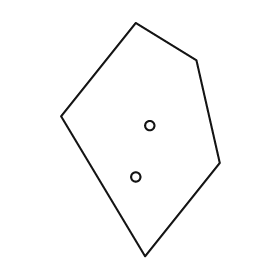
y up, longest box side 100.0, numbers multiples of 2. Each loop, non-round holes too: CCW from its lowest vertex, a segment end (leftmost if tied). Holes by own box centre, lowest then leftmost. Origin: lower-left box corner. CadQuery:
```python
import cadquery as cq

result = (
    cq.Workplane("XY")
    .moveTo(36.0, 0.0)
    .lineTo(68.0, 40.0)
    .lineTo(58.0, 84.0)
    .lineTo(32.0, 100.0)
    .lineTo(0.0, 60.0)
    .close()
    .moveTo(32.0, 34.0)
    .circle(2.0)
    .moveTo(38.0, 56.0)
    .circle(2.0)
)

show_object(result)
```